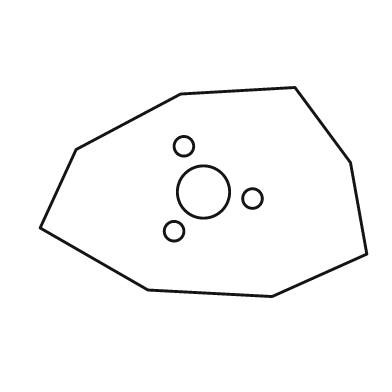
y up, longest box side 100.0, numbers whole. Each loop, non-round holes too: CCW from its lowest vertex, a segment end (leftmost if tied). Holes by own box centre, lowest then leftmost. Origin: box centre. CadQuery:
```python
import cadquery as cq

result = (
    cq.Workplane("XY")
    .moveTo(21.0, -32.0)
    .lineTo(50.0, -19.0)
    .lineTo(45.0, 9.0)
    .lineTo(28.0, 32.0)
    .lineTo(-7.0, 30.0)
    .lineTo(-39.0, 13.0)
    .lineTo(-50.0, -11.0)
    .lineTo(-17.0, -30.0)
    .close()
    .moveTo(-9.0, -12.0)
    .circle(3.0)
    .moveTo(15.0, -2.0)
    .circle(3.0)
    .moveTo(0.0, 0.0)
    .circle(8.0)
    .moveTo(-6.0, 14.0)
    .circle(3.0)
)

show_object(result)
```